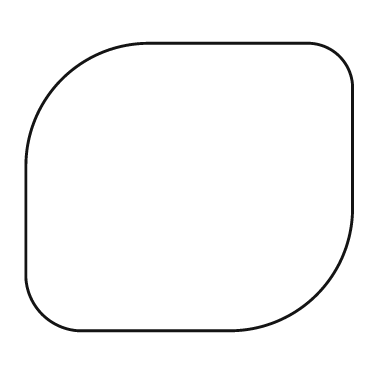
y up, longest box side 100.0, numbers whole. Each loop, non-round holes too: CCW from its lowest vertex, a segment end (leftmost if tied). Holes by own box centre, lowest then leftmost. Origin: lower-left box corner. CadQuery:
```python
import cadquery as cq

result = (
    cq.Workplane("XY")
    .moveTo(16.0, 0.0)
    .lineTo(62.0, 0.0)
    .threePointArc((89.0, 11.0), (100.0, 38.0))
    .lineTo(100.0, 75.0)
    .threePointArc((96.0, 84.0), (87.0, 88.0))
    .lineTo(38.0, 88.0)
    .threePointArc((11.0, 77.0), (0.0, 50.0))
    .lineTo(0.0, 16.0)
    .threePointArc((5.0, 5.0), (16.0, 0.0))
    .close()
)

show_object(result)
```